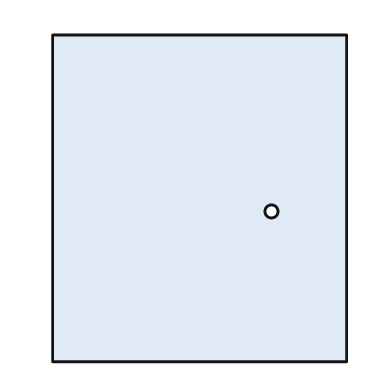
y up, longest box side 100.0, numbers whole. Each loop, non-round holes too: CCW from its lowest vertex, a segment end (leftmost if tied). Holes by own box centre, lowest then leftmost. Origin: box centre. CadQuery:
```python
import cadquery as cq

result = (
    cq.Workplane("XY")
    .moveTo(-45.0, -50.0)
    .lineTo(45.0, -50.0)
    .lineTo(45.0, 50.0)
    .lineTo(-45.0, 50.0)
    .close()
    .moveTo(22.0, -4.0)
    .circle(2.0)
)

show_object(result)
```